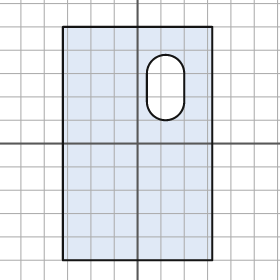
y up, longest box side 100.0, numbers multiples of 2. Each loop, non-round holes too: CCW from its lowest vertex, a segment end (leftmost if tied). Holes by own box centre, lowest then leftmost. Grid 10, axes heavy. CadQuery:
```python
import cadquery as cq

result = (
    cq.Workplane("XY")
    .moveTo(-32.0, -50.0)
    .lineTo(32.0, -50.0)
    .lineTo(32.0, 50.0)
    .lineTo(-32.0, 50.0)
    .close()
    .moveTo(4.0, 18.0)
    .threePointArc((12.0, 10.0), (20.0, 18.0))
    .lineTo(20.0, 30.0)
    .threePointArc((12.0, 38.0), (4.0, 30.0))
    .close()
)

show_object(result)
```